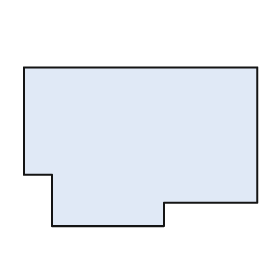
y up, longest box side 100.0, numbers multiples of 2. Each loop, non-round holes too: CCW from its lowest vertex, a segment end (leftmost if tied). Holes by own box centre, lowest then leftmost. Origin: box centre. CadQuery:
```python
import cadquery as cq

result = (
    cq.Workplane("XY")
    .moveTo(-38.0, -34.0)
    .lineTo(10.0, -34.0)
    .lineTo(10.0, -24.0)
    .lineTo(50.0, -24.0)
    .lineTo(50.0, 34.0)
    .lineTo(-50.0, 34.0)
    .lineTo(-50.0, -12.0)
    .lineTo(-38.0, -12.0)
    .close()
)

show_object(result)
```